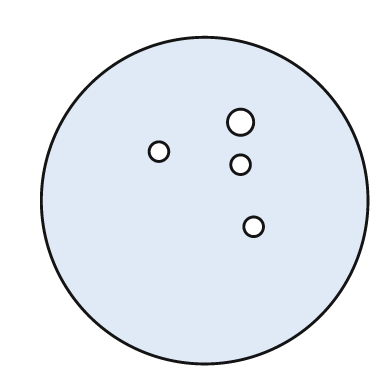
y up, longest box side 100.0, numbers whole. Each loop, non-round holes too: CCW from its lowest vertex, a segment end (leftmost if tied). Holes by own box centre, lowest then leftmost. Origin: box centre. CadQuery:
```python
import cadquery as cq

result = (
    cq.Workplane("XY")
    .moveTo(0.0, 0.0)
    .circle(50.0)
    .moveTo(15.0, -8.0)
    .circle(3.0)
    .moveTo(11.0, 11.0)
    .circle(3.0)
    .moveTo(-14.0, 15.0)
    .circle(3.0)
    .moveTo(11.0, 24.0)
    .circle(4.0)
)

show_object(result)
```